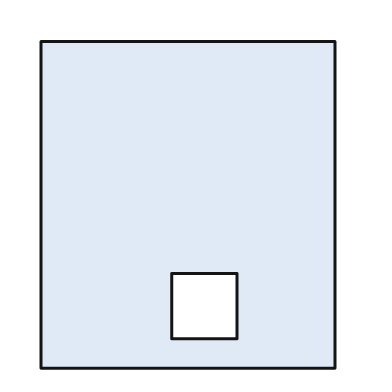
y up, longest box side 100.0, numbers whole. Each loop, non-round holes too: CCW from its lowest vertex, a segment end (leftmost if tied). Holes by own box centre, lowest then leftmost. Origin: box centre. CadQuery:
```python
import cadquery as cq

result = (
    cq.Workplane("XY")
    .moveTo(-45.0, -50.0)
    .lineTo(45.0, -50.0)
    .lineTo(45.0, 50.0)
    .lineTo(-45.0, 50.0)
    .close()
    .moveTo(-5.0, -41.0)
    .lineTo(15.0, -41.0)
    .lineTo(15.0, -21.0)
    .lineTo(-5.0, -21.0)
    .close()
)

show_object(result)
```